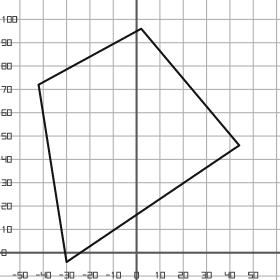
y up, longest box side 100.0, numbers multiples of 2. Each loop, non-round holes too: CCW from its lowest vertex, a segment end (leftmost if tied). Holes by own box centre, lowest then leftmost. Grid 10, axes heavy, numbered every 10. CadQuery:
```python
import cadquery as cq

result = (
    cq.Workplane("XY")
    .moveTo(-30.0, -4.0)
    .lineTo(44.0, 46.0)
    .lineTo(2.0, 96.0)
    .lineTo(-42.0, 72.0)
    .close()
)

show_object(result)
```